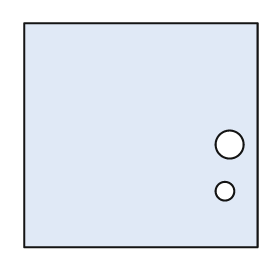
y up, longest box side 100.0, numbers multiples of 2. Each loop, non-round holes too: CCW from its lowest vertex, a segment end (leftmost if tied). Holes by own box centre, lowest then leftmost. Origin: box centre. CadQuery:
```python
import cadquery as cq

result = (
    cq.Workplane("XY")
    .moveTo(-50.0, -48.0)
    .lineTo(50.0, -48.0)
    .lineTo(50.0, 48.0)
    .lineTo(-50.0, 48.0)
    .close()
    .moveTo(36.0, -24.0)
    .circle(4.0)
    .moveTo(38.0, -4.0)
    .circle(6.0)
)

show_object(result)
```